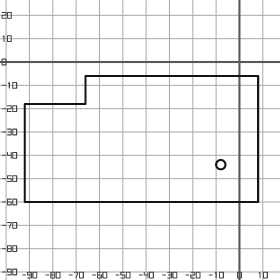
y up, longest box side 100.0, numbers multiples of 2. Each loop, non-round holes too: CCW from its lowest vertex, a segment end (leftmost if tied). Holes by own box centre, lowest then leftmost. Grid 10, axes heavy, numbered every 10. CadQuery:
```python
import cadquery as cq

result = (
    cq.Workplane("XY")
    .moveTo(-92.0, -60.0)
    .lineTo(8.0, -60.0)
    .lineTo(8.0, -6.0)
    .lineTo(-66.0, -6.0)
    .lineTo(-66.0, -18.0)
    .lineTo(-92.0, -18.0)
    .close()
    .moveTo(-8.0, -44.0)
    .circle(2.0)
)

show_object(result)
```